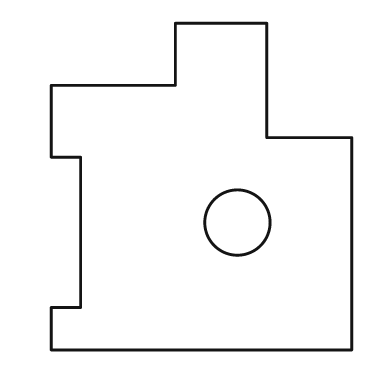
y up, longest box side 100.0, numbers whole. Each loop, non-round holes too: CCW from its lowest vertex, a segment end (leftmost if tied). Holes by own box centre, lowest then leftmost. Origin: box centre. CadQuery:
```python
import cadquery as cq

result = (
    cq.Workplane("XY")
    .moveTo(-46.0, -50.0)
    .lineTo(46.0, -50.0)
    .lineTo(46.0, 15.0)
    .lineTo(20.0, 15.0)
    .lineTo(20.0, 50.0)
    .lineTo(-8.0, 50.0)
    .lineTo(-8.0, 31.0)
    .lineTo(-46.0, 31.0)
    .lineTo(-46.0, 9.0)
    .lineTo(-37.0, 9.0)
    .lineTo(-37.0, -37.0)
    .lineTo(-46.0, -37.0)
    .close()
    .moveTo(11.0, -11.0)
    .circle(10.0)
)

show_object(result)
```